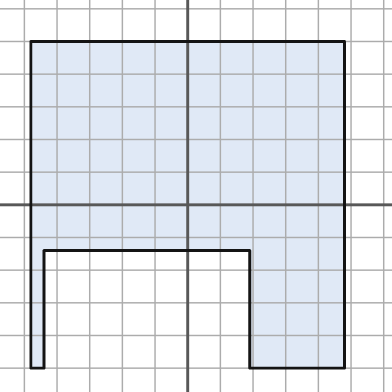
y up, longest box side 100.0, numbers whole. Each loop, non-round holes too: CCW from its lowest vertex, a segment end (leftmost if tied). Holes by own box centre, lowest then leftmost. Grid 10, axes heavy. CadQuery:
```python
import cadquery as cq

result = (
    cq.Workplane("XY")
    .moveTo(-48.0, -50.0)
    .lineTo(-44.0, -50.0)
    .lineTo(-44.0, -14.0)
    .lineTo(19.0, -14.0)
    .lineTo(19.0, -50.0)
    .lineTo(48.0, -50.0)
    .lineTo(48.0, 50.0)
    .lineTo(-48.0, 50.0)
    .close()
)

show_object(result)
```